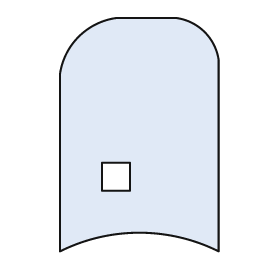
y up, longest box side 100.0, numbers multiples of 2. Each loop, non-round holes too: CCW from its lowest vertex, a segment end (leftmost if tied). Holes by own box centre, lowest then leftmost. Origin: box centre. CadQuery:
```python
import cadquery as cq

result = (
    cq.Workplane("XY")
    .moveTo(-34.0, -50.0)
    .threePointArc((0.0, -42.0), (34.0, -50.0))
    .lineTo(34.0, 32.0)
    .threePointArc((28.0, 44.0), (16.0, 50.0))
    .lineTo(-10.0, 50.0)
    .threePointArc((-26.0, 42.0), (-34.0, 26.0))
    .close()
    .moveTo(-16.0, -24.0)
    .lineTo(-4.0, -24.0)
    .lineTo(-4.0, -12.0)
    .lineTo(-16.0, -12.0)
    .close()
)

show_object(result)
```